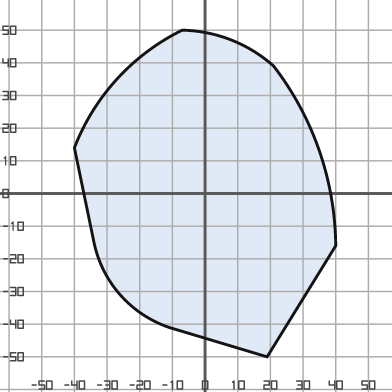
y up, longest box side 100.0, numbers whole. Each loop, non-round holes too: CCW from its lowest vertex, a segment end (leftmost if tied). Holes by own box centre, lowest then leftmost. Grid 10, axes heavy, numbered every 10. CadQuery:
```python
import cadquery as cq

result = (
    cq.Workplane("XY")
    .moveTo(19.0, -50.0)
    .lineTo(40.0, -16.0)
    .threePointArc((35.0, 13.0), (21.0, 39.0))
    .threePointArc((8.0, 47.0), (-7.0, 50.0))
    .threePointArc((-27.0, 35.0), (-40.0, 14.0))
    .lineTo(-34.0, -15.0)
    .threePointArc((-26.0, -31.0), (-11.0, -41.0))
    .close()
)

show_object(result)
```